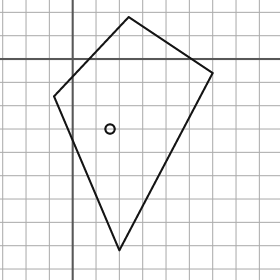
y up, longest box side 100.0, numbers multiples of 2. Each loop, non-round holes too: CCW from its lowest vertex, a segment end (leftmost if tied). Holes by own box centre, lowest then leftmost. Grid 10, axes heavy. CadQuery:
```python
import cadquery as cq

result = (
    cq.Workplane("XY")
    .moveTo(20.0, -82.0)
    .lineTo(60.0, -6.0)
    .lineTo(24.0, 18.0)
    .lineTo(-8.0, -16.0)
    .close()
    .moveTo(16.0, -30.0)
    .circle(2.0)
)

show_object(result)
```